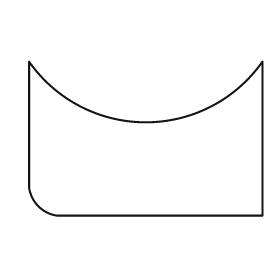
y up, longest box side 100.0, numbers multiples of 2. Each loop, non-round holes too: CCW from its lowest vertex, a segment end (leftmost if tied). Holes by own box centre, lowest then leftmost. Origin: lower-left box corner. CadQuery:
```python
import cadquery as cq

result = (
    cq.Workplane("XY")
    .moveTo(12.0, 0.0)
    .lineTo(100.0, 0.0)
    .lineTo(100.0, 66.0)
    .threePointArc((50.0, 40.0), (0.0, 66.0))
    .lineTo(0.0, 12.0)
    .threePointArc((4.0, 4.0), (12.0, 0.0))
    .close()
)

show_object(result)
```